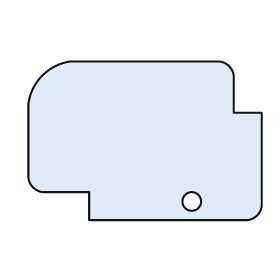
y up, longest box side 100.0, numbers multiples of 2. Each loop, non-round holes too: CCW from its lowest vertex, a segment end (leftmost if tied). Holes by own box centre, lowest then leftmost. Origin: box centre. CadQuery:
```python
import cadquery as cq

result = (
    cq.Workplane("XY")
    .moveTo(-24.0, -34.0)
    .lineTo(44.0, -34.0)
    .threePointArc((48.0, -32.0), (50.0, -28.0))
    .lineTo(50.0, 12.0)
    .lineTo(38.0, 12.0)
    .lineTo(38.0, 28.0)
    .threePointArc((36.0, 32.0), (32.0, 34.0))
    .lineTo(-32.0, 34.0)
    .threePointArc((-44.0, 28.0), (-50.0, 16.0))
    .lineTo(-50.0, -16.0)
    .threePointArc((-48.0, -20.0), (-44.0, -22.0))
    .lineTo(-24.0, -22.0)
    .close()
    .moveTo(20.0, -26.0)
    .circle(4.0)
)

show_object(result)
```